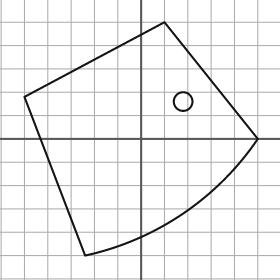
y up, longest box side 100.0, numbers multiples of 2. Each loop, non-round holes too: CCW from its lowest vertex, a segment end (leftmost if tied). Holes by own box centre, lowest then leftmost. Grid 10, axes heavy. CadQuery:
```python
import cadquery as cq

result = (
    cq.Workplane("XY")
    .moveTo(-24.0, -50.0)
    .threePointArc((18.0, -32.0), (50.0, 0.0))
    .lineTo(10.0, 50.0)
    .lineTo(-50.0, 18.0)
    .close()
    .moveTo(18.0, 16.0)
    .circle(4.0)
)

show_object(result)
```